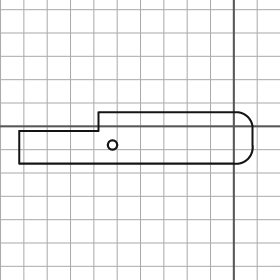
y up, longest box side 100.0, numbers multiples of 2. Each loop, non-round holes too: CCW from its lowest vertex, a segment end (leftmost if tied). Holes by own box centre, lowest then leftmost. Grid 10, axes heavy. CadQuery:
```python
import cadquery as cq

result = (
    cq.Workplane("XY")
    .moveTo(-92.0, -16.0)
    .lineTo(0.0, -16.0)
    .threePointArc((6.0, -14.0), (8.0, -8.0))
    .lineTo(8.0, 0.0)
    .threePointArc((6.0, 4.0), (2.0, 6.0))
    .lineTo(-58.0, 6.0)
    .lineTo(-58.0, -2.0)
    .lineTo(-92.0, -2.0)
    .close()
    .moveTo(-52.0, -8.0)
    .circle(2.0)
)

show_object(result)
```